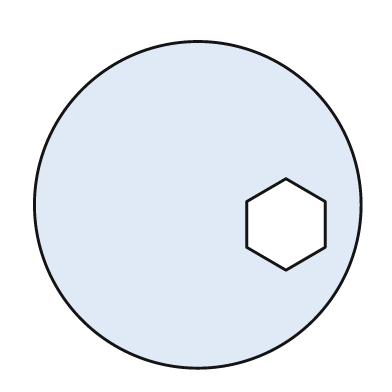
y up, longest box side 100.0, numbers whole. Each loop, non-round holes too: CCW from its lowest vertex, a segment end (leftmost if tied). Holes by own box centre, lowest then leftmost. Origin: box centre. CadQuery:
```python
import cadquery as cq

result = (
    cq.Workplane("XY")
    .moveTo(0.0, 0.0)
    .circle(50.0)
    .moveTo(27.0, -20.0)
    .lineTo(39.0, -13.0)
    .lineTo(39.0, 1.0)
    .lineTo(27.0, 8.0)
    .lineTo(15.0, 1.0)
    .lineTo(15.0, -13.0)
    .close()
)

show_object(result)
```